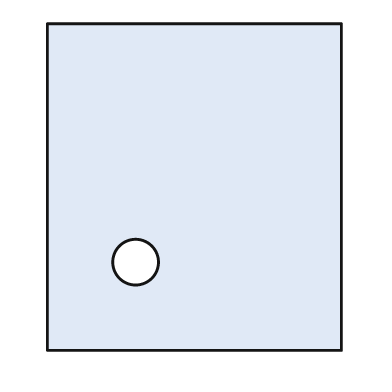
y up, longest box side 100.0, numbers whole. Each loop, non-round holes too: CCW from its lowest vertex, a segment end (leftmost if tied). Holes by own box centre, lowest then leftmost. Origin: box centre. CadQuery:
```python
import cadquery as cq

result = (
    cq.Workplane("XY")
    .moveTo(-45.0, -50.0)
    .lineTo(45.0, -50.0)
    .lineTo(45.0, 50.0)
    .lineTo(-45.0, 50.0)
    .close()
    .moveTo(-18.0, -23.0)
    .circle(7.0)
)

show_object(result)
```